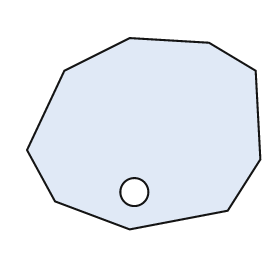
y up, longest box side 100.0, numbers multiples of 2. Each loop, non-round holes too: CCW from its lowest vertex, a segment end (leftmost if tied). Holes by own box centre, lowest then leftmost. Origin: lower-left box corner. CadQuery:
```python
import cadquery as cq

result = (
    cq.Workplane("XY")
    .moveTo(44.0, 0.0)
    .lineTo(86.0, 8.0)
    .lineTo(100.0, 30.0)
    .lineTo(98.0, 68.0)
    .lineTo(78.0, 80.0)
    .lineTo(44.0, 82.0)
    .lineTo(16.0, 68.0)
    .lineTo(0.0, 34.0)
    .lineTo(12.0, 12.0)
    .close()
    .moveTo(46.0, 16.0)
    .circle(6.0)
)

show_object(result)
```